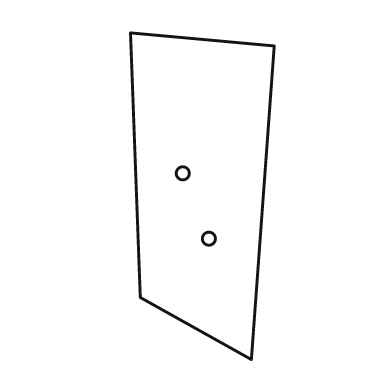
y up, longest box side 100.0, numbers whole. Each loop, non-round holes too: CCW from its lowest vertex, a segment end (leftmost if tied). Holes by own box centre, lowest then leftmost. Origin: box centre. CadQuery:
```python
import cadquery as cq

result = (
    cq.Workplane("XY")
    .moveTo(15.0, -50.0)
    .lineTo(22.0, 46.0)
    .lineTo(-22.0, 50.0)
    .lineTo(-19.0, -31.0)
    .close()
    .moveTo(2.0, -13.0)
    .circle(2.0)
    .moveTo(-6.0, 7.0)
    .circle(2.0)
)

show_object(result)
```